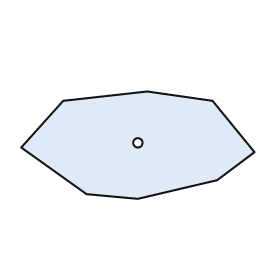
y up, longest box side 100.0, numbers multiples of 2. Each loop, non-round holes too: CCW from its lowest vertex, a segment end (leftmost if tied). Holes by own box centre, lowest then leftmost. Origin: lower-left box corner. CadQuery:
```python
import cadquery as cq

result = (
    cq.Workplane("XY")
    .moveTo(50.0, 0.0)
    .lineTo(84.0, 8.0)
    .lineTo(100.0, 20.0)
    .lineTo(82.0, 42.0)
    .lineTo(54.0, 46.0)
    .lineTo(18.0, 42.0)
    .lineTo(0.0, 22.0)
    .lineTo(28.0, 2.0)
    .close()
    .moveTo(50.0, 24.0)
    .circle(2.0)
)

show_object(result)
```